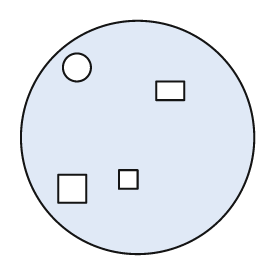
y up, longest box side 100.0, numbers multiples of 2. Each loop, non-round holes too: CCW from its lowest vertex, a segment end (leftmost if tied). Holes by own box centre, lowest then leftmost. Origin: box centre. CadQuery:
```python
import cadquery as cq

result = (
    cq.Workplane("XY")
    .moveTo(0.0, 0.0)
    .circle(50.0)
    .moveTo(-34.0, -28.0)
    .lineTo(-22.0, -28.0)
    .lineTo(-22.0, -16.0)
    .lineTo(-34.0, -16.0)
    .close()
    .moveTo(-8.0, -22.0)
    .lineTo(0.0, -22.0)
    .lineTo(0.0, -14.0)
    .lineTo(-8.0, -14.0)
    .close()
    .moveTo(8.0, 16.0)
    .lineTo(20.0, 16.0)
    .lineTo(20.0, 24.0)
    .lineTo(8.0, 24.0)
    .close()
    .moveTo(-26.0, 30.0)
    .circle(6.0)
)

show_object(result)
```